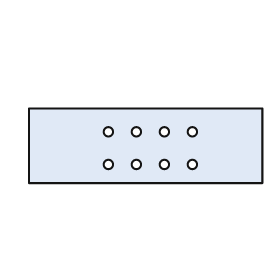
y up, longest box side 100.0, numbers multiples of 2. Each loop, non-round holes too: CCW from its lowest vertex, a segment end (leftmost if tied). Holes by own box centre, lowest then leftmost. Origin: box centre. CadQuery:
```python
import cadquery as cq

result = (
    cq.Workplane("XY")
    .moveTo(-50.0, -16.0)
    .lineTo(50.0, -16.0)
    .lineTo(50.0, 16.0)
    .lineTo(-50.0, 16.0)
    .close()
    .moveTo(-16.0, -8.0)
    .circle(2.0)
    .moveTo(-4.0, -8.0)
    .circle(2.0)
    .moveTo(8.0, -8.0)
    .circle(2.0)
    .moveTo(20.0, -8.0)
    .circle(2.0)
    .moveTo(-16.0, 6.0)
    .circle(2.0)
    .moveTo(-4.0, 6.0)
    .circle(2.0)
    .moveTo(8.0, 6.0)
    .circle(2.0)
    .moveTo(20.0, 6.0)
    .circle(2.0)
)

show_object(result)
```